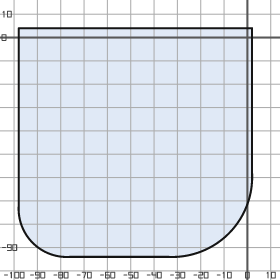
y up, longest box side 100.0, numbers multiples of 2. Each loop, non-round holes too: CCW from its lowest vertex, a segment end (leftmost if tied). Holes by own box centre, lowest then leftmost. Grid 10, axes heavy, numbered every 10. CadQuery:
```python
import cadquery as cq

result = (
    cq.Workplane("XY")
    .moveTo(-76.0, -94.0)
    .lineTo(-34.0, -94.0)
    .threePointArc((-8.0, -84.0), (2.0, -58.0))
    .lineTo(2.0, 4.0)
    .lineTo(-98.0, 4.0)
    .lineTo(-98.0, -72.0)
    .threePointArc((-92.0, -88.0), (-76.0, -94.0))
    .close()
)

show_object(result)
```